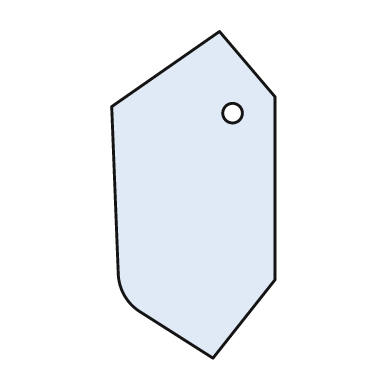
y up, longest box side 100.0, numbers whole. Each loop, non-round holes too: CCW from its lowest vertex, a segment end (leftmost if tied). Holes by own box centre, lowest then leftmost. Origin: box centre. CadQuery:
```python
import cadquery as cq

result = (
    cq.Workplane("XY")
    .moveTo(6.0, -50.0)
    .lineTo(25.0, -26.0)
    .lineTo(25.0, 30.0)
    .lineTo(8.0, 50.0)
    .lineTo(-25.0, 27.0)
    .lineTo(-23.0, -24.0)
    .threePointArc((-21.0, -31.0), (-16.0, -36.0))
    .close()
    .moveTo(12.0, 25.0)
    .circle(3.0)
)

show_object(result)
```